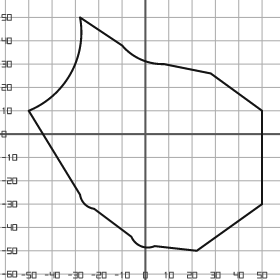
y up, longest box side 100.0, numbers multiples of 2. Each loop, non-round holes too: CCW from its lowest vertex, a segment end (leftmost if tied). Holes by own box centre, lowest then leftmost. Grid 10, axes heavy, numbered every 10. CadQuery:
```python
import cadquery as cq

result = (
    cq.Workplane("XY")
    .moveTo(22.0, -50.0)
    .lineTo(50.0, -30.0)
    .lineTo(50.0, 10.0)
    .lineTo(28.0, 26.0)
    .lineTo(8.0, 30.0)
    .threePointArc((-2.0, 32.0), (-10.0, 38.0))
    .lineTo(-28.0, 50.0)
    .threePointArc((-32.0, 26.0), (-50.0, 10.0))
    .lineTo(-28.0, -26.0)
    .threePointArc((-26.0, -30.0), (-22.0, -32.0))
    .lineTo(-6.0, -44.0)
    .threePointArc((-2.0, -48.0), (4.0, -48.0))
    .close()
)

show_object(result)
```